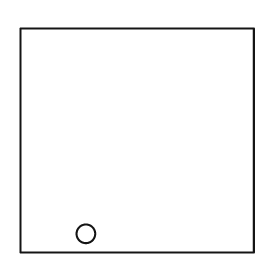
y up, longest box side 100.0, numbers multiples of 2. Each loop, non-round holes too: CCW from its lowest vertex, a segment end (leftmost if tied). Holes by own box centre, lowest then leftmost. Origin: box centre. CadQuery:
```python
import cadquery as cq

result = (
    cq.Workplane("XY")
    .moveTo(-50.0, -48.0)
    .lineTo(50.0, -48.0)
    .lineTo(50.0, 48.0)
    .lineTo(-50.0, 48.0)
    .close()
    .moveTo(-22.0, -40.0)
    .circle(4.0)
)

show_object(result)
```